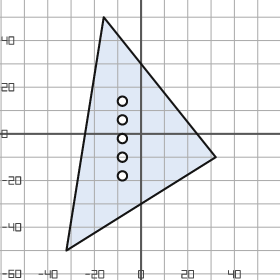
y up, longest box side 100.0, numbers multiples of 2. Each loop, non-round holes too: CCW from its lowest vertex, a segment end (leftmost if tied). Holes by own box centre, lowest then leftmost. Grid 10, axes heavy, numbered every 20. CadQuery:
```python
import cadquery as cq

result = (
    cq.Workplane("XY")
    .moveTo(-32.0, -50.0)
    .lineTo(32.0, -10.0)
    .lineTo(-16.0, 50.0)
    .close()
    .moveTo(-8.0, -18.0)
    .circle(2.0)
    .moveTo(-8.0, -10.0)
    .circle(2.0)
    .moveTo(-8.0, -2.0)
    .circle(2.0)
    .moveTo(-8.0, 6.0)
    .circle(2.0)
    .moveTo(-8.0, 14.0)
    .circle(2.0)
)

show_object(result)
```